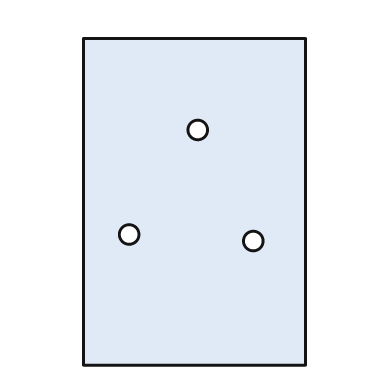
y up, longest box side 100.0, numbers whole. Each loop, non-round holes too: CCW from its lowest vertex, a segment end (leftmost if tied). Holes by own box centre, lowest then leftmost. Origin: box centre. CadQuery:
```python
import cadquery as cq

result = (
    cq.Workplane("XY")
    .moveTo(-34.0, -50.0)
    .lineTo(34.0, -50.0)
    .lineTo(34.0, 50.0)
    .lineTo(-34.0, 50.0)
    .close()
    .moveTo(18.0, -12.0)
    .circle(3.0)
    .moveTo(-20.0, -10.0)
    .circle(3.0)
    .moveTo(1.0, 22.0)
    .circle(3.0)
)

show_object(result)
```